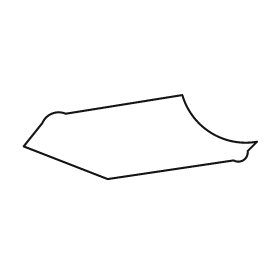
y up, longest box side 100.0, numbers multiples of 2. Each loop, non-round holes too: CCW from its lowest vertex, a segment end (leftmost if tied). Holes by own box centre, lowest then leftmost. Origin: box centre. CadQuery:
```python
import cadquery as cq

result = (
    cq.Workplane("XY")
    .moveTo(-14.0, -18.0)
    .lineTo(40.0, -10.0)
    .threePointArc((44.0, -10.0), (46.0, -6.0))
    .lineTo(50.0, -2.0)
    .threePointArc((30.0, 2.0), (18.0, 18.0))
    .lineTo(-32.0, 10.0)
    .threePointArc((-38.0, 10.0), (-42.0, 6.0))
    .lineTo(-50.0, -4.0)
    .close()
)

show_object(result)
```